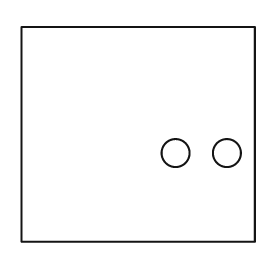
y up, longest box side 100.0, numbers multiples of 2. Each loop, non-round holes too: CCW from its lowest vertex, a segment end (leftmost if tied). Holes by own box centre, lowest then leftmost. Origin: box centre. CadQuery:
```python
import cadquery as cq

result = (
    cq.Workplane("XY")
    .moveTo(-50.0, -46.0)
    .lineTo(50.0, -46.0)
    .lineTo(50.0, 46.0)
    .lineTo(-50.0, 46.0)
    .close()
    .moveTo(16.0, -8.0)
    .circle(6.0)
    .moveTo(38.0, -8.0)
    .circle(6.0)
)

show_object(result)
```